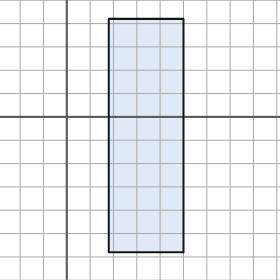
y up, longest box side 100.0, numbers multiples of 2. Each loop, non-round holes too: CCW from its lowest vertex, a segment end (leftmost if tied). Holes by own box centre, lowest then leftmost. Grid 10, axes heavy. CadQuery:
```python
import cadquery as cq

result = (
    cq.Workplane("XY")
    .moveTo(18.0, -58.0)
    .lineTo(50.0, -58.0)
    .lineTo(50.0, 42.0)
    .lineTo(18.0, 42.0)
    .close()
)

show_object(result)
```